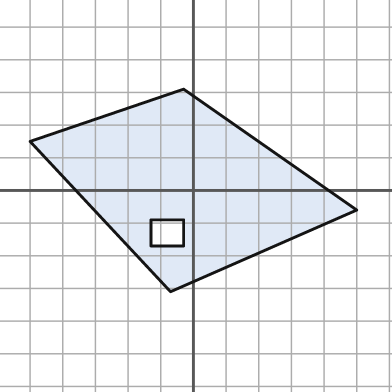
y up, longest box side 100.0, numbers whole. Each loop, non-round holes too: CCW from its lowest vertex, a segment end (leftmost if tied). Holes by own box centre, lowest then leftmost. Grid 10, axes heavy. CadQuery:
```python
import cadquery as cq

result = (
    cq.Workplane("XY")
    .moveTo(-7.0, -31.0)
    .lineTo(50.0, -6.0)
    .lineTo(-3.0, 31.0)
    .lineTo(-50.0, 15.0)
    .close()
    .moveTo(-13.0, -17.0)
    .lineTo(-3.0, -17.0)
    .lineTo(-3.0, -9.0)
    .lineTo(-13.0, -9.0)
    .close()
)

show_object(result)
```